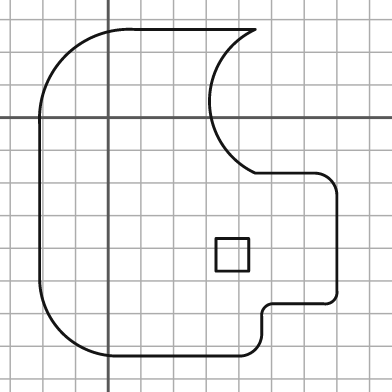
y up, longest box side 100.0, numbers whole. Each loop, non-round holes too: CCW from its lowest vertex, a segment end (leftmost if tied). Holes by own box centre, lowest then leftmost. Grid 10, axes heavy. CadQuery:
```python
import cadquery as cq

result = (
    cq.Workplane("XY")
    .moveTo(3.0, -73.0)
    .lineTo(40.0, -73.0)
    .threePointArc((45.0, -71.0), (47.0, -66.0))
    .lineTo(47.0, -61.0)
    .threePointArc((48.0, -58.0), (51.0, -57.0))
    .lineTo(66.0, -57.0)
    .threePointArc((69.0, -56.0), (70.0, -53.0))
    .lineTo(70.0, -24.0)
    .threePointArc((68.0, -19.0), (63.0, -17.0))
    .lineTo(45.0, -17.0)
    .threePointArc((31.0, 5.0), (45.0, 27.0))
    .lineTo(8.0, 27.0)
    .threePointArc((-13.0, 19.0), (-21.0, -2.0))
    .lineTo(-21.0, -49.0)
    .threePointArc((-14.0, -66.0), (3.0, -73.0))
    .close()
    .moveTo(33.0, -47.0)
    .lineTo(43.0, -47.0)
    .lineTo(43.0, -37.0)
    .lineTo(33.0, -37.0)
    .close()
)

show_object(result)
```